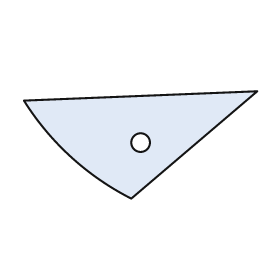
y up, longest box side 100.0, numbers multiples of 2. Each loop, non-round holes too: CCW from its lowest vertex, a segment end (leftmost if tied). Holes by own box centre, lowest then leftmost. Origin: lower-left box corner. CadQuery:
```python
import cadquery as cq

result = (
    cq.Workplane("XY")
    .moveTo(46.0, 0.0)
    .lineTo(100.0, 46.0)
    .lineTo(0.0, 42.0)
    .threePointArc((20.0, 18.0), (46.0, 0.0))
    .close()
    .moveTo(50.0, 24.0)
    .circle(4.0)
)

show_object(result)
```